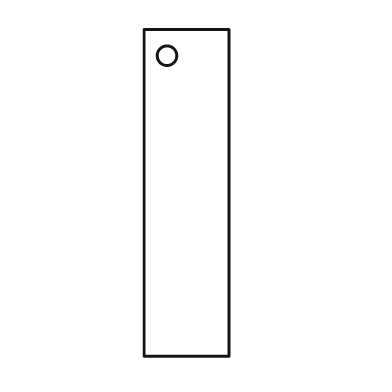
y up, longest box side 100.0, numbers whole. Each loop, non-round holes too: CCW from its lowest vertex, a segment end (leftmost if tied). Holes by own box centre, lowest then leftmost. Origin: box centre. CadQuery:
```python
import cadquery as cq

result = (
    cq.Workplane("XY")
    .moveTo(-13.0, -50.0)
    .lineTo(13.0, -50.0)
    .lineTo(13.0, 50.0)
    .lineTo(-13.0, 50.0)
    .close()
    .moveTo(-6.0, 42.0)
    .circle(3.0)
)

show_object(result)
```